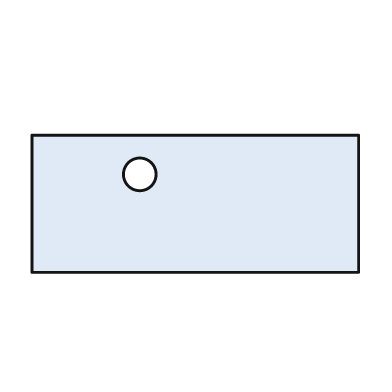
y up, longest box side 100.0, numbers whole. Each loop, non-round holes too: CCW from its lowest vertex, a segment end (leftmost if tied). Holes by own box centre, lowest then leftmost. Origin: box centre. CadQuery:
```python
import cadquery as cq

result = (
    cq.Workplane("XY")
    .moveTo(-50.0, -21.0)
    .lineTo(50.0, -21.0)
    .lineTo(50.0, 21.0)
    .lineTo(-50.0, 21.0)
    .close()
    .moveTo(-17.0, 9.0)
    .circle(5.0)
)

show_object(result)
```